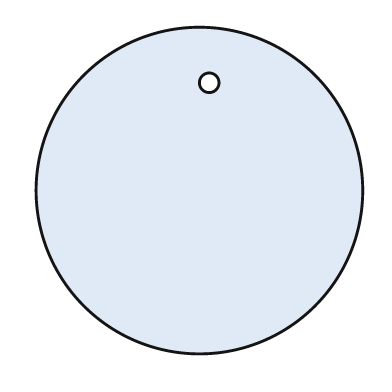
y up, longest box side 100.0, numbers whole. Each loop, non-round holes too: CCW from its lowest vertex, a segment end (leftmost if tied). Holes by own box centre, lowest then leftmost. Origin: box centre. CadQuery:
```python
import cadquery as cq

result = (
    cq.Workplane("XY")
    .moveTo(0.0, 0.0)
    .circle(50.0)
    .moveTo(3.0, 33.0)
    .circle(3.0)
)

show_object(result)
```